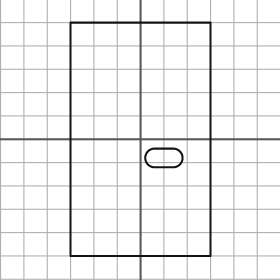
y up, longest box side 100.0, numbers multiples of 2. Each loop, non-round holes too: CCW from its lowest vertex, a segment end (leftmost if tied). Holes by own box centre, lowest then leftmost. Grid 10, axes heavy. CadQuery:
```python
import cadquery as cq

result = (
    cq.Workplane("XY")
    .moveTo(-30.0, -50.0)
    .lineTo(30.0, -50.0)
    .lineTo(30.0, 50.0)
    .lineTo(-30.0, 50.0)
    .close()
    .moveTo(6.0, -12.0)
    .lineTo(14.0, -12.0)
    .threePointArc((18.0, -8.0), (14.0, -4.0))
    .lineTo(6.0, -4.0)
    .threePointArc((2.0, -8.0), (6.0, -12.0))
    .close()
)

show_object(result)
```